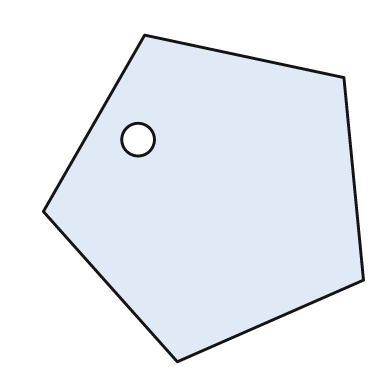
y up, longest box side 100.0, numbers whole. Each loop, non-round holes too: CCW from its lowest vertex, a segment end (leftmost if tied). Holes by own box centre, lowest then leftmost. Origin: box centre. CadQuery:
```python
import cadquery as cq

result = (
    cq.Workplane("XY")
    .moveTo(-8.0, -50.0)
    .lineTo(49.0, -25.0)
    .lineTo(43.0, 37.0)
    .lineTo(-18.0, 50.0)
    .lineTo(-49.0, -4.0)
    .close()
    .moveTo(-20.0, 18.0)
    .circle(5.0)
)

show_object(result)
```